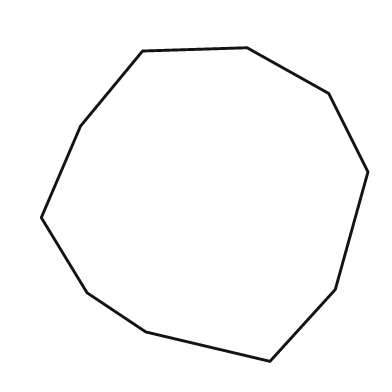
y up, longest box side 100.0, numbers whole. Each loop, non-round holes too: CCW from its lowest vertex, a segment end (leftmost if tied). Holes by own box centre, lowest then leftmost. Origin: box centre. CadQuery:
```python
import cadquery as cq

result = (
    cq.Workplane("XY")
    .moveTo(20.0, -48.0)
    .lineTo(40.0, -26.0)
    .lineTo(50.0, 10.0)
    .lineTo(38.0, 34.0)
    .lineTo(13.0, 48.0)
    .lineTo(-19.0, 47.0)
    .lineTo(-38.0, 24.0)
    .lineTo(-50.0, -4.0)
    .lineTo(-36.0, -27.0)
    .lineTo(-18.0, -39.0)
    .close()
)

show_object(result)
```